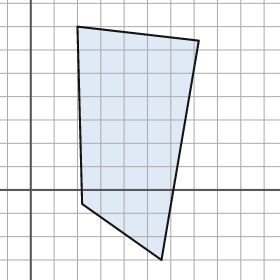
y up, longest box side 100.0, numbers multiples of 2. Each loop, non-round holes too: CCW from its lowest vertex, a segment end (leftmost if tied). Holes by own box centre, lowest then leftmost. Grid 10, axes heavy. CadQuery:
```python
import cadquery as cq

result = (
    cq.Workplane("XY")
    .moveTo(56.0, -30.0)
    .lineTo(72.0, 64.0)
    .lineTo(20.0, 70.0)
    .lineTo(22.0, -6.0)
    .close()
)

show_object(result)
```